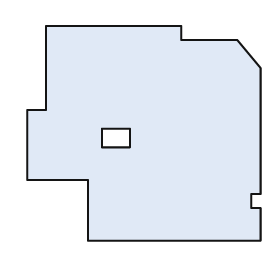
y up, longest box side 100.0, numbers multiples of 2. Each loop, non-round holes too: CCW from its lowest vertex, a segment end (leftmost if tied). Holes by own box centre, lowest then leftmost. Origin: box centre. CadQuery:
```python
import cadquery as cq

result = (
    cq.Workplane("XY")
    .moveTo(-24.0, -46.0)
    .lineTo(50.0, -46.0)
    .lineTo(50.0, -32.0)
    .lineTo(46.0, -32.0)
    .lineTo(46.0, -26.0)
    .lineTo(50.0, -26.0)
    .lineTo(50.0, 28.0)
    .lineTo(40.0, 40.0)
    .lineTo(16.0, 40.0)
    .lineTo(16.0, 46.0)
    .lineTo(-42.0, 46.0)
    .lineTo(-42.0, 10.0)
    .lineTo(-50.0, 10.0)
    .lineTo(-50.0, -20.0)
    .lineTo(-24.0, -20.0)
    .close()
    .moveTo(-18.0, -6.0)
    .lineTo(-6.0, -6.0)
    .lineTo(-6.0, 2.0)
    .lineTo(-18.0, 2.0)
    .close()
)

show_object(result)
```